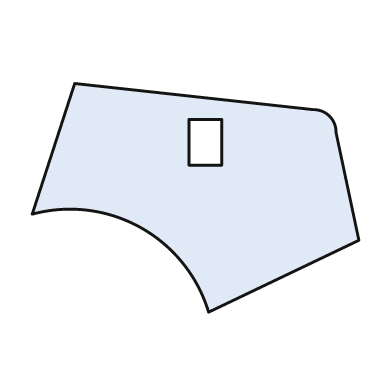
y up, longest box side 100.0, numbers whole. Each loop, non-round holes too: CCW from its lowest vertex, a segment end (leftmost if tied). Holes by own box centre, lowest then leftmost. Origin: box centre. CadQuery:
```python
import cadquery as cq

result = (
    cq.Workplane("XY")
    .moveTo(4.0, -35.0)
    .lineTo(50.0, -13.0)
    .lineTo(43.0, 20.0)
    .threePointArc((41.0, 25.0), (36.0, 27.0))
    .lineTo(-37.0, 35.0)
    .lineTo(-50.0, -5.0)
    .threePointArc((-17.0, -9.0), (4.0, -35.0))
    .close()
    .moveTo(-2.0, 10.0)
    .lineTo(8.0, 10.0)
    .lineTo(8.0, 24.0)
    .lineTo(-2.0, 24.0)
    .close()
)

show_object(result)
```